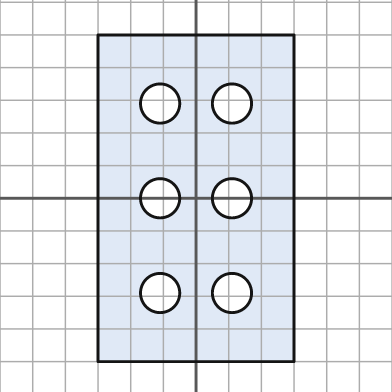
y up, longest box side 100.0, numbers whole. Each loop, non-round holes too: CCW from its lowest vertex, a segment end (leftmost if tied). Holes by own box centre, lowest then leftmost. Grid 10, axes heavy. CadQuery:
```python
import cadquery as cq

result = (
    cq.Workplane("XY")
    .moveTo(-30.0, -50.0)
    .lineTo(30.0, -50.0)
    .lineTo(30.0, 50.0)
    .lineTo(-30.0, 50.0)
    .close()
    .moveTo(-11.0, -29.0)
    .circle(6.0)
    .moveTo(11.0, -29.0)
    .circle(6.0)
    .moveTo(-11.0, 0.0)
    .circle(6.0)
    .moveTo(11.0, 0.0)
    .circle(6.0)
    .moveTo(-11.0, 29.0)
    .circle(6.0)
    .moveTo(11.0, 29.0)
    .circle(6.0)
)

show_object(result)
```